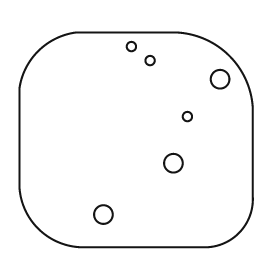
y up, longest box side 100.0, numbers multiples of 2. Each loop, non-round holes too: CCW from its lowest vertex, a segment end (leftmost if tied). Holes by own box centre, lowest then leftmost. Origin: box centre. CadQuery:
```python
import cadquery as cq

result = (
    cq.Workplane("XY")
    .moveTo(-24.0, -46.0)
    .lineTo(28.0, -46.0)
    .threePointArc((44.0, -40.0), (50.0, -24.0))
    .lineTo(50.0, 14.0)
    .threePointArc((40.0, 36.0), (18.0, 46.0))
    .lineTo(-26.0, 46.0)
    .threePointArc((-42.0, 38.0), (-50.0, 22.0))
    .lineTo(-50.0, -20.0)
    .threePointArc((-42.0, -38.0), (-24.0, -46.0))
    .close()
    .moveTo(-14.0, -32.0)
    .circle(4.0)
    .moveTo(16.0, -10.0)
    .circle(4.0)
    .moveTo(22.0, 10.0)
    .circle(2.0)
    .moveTo(36.0, 26.0)
    .circle(4.0)
    .moveTo(6.0, 34.0)
    .circle(2.0)
    .moveTo(-2.0, 40.0)
    .circle(2.0)
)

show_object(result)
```